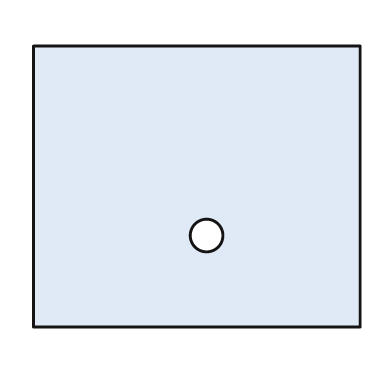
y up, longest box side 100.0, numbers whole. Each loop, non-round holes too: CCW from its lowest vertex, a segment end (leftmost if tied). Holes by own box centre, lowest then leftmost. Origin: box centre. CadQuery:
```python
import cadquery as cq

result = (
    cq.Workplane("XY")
    .moveTo(-50.0, -43.0)
    .lineTo(50.0, -43.0)
    .lineTo(50.0, 43.0)
    .lineTo(-50.0, 43.0)
    .close()
    .moveTo(3.0, -15.0)
    .circle(5.0)
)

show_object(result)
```